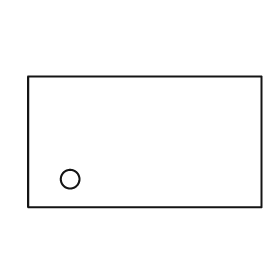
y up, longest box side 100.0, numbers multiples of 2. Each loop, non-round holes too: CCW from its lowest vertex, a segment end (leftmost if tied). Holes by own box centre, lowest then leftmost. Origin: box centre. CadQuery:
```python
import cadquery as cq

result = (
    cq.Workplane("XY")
    .moveTo(-50.0, -28.0)
    .lineTo(50.0, -28.0)
    .lineTo(50.0, 28.0)
    .lineTo(-50.0, 28.0)
    .close()
    .moveTo(-32.0, -16.0)
    .circle(4.0)
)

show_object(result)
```